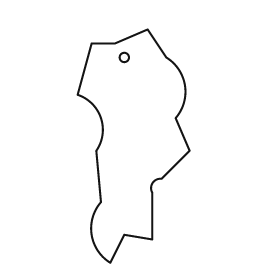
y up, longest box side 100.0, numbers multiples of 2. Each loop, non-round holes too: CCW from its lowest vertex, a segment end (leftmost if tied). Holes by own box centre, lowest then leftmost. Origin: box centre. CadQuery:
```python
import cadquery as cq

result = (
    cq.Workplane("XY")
    .moveTo(-10.0, -50.0)
    .lineTo(-4.0, -38.0)
    .lineTo(8.0, -40.0)
    .lineTo(8.0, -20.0)
    .threePointArc((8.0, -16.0), (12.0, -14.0))
    .lineTo(24.0, -2.0)
    .lineTo(18.0, 12.0)
    .threePointArc((22.0, 26.0), (14.0, 38.0))
    .lineTo(6.0, 50.0)
    .lineTo(-8.0, 44.0)
    .lineTo(-18.0, 44.0)
    .lineTo(-24.0, 22.0)
    .threePointArc((-14.0, 12.0), (-16.0, -2.0))
    .lineTo(-14.0, -24.0)
    .threePointArc((-18.0, -38.0), (-10.0, -50.0))
    .close()
    .moveTo(-4.0, 38.0)
    .circle(2.0)
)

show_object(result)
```